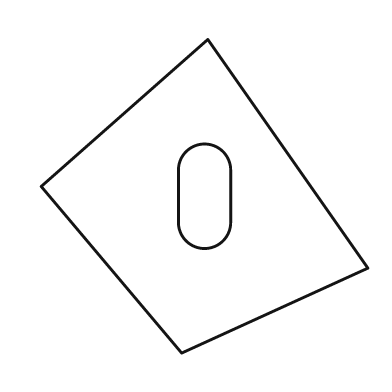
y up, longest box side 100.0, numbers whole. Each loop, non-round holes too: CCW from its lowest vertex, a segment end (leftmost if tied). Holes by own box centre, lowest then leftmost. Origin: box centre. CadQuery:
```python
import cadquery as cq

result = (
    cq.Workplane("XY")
    .moveTo(-7.0, -48.0)
    .lineTo(50.0, -22.0)
    .lineTo(1.0, 48.0)
    .lineTo(-50.0, 3.0)
    .close()
    .moveTo(-8.0, -8.0)
    .threePointArc((0.0, -16.0), (8.0, -8.0))
    .lineTo(8.0, 8.0)
    .threePointArc((0.0, 16.0), (-8.0, 8.0))
    .close()
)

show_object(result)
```